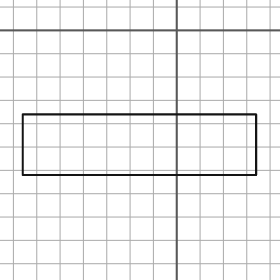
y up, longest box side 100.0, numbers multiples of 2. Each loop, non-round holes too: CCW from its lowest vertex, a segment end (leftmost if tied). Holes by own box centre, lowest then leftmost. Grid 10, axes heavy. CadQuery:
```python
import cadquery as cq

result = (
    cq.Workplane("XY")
    .moveTo(-66.0, -62.0)
    .lineTo(34.0, -62.0)
    .lineTo(34.0, -36.0)
    .lineTo(-66.0, -36.0)
    .close()
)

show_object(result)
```